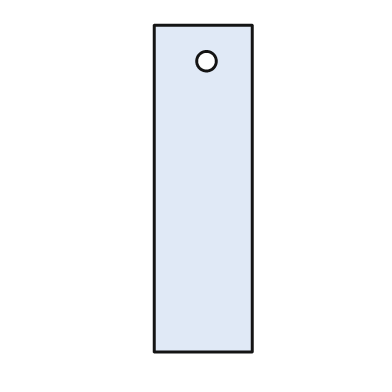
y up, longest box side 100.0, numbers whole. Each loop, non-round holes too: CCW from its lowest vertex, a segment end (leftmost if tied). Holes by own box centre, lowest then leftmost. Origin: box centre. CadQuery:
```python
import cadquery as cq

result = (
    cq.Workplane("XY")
    .moveTo(-15.0, -50.0)
    .lineTo(15.0, -50.0)
    .lineTo(15.0, 50.0)
    .lineTo(-15.0, 50.0)
    .close()
    .moveTo(1.0, 39.0)
    .circle(3.0)
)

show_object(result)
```